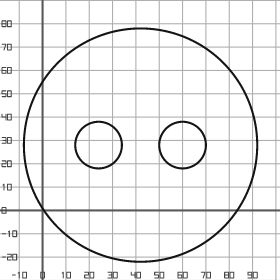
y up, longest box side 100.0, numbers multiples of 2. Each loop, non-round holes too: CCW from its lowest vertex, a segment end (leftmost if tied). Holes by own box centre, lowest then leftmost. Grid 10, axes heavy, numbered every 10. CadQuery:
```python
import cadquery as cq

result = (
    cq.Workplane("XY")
    .moveTo(42.0, 28.0)
    .circle(50.0)
    .moveTo(24.0, 28.0)
    .circle(10.0)
    .moveTo(60.0, 28.0)
    .circle(10.0)
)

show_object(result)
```